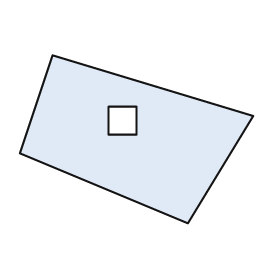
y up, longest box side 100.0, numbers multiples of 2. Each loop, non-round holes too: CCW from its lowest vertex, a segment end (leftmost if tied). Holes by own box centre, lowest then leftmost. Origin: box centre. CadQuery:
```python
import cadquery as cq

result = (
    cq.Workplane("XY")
    .moveTo(22.0, -36.0)
    .lineTo(50.0, 10.0)
    .lineTo(-36.0, 36.0)
    .lineTo(-50.0, -6.0)
    .close()
    .moveTo(-12.0, 2.0)
    .lineTo(0.0, 2.0)
    .lineTo(0.0, 14.0)
    .lineTo(-12.0, 14.0)
    .close()
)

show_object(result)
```